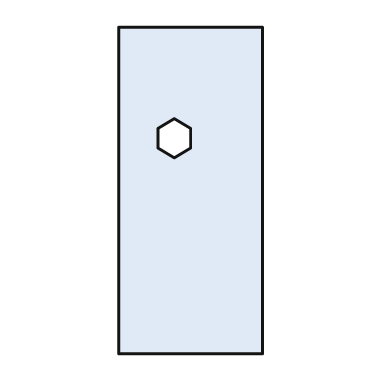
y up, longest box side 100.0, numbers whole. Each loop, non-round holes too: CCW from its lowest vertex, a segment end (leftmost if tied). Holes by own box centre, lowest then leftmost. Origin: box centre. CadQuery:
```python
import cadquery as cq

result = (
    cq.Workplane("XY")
    .moveTo(-22.0, -50.0)
    .lineTo(22.0, -50.0)
    .lineTo(22.0, 50.0)
    .lineTo(-22.0, 50.0)
    .close()
    .moveTo(-5.0, 10.0)
    .lineTo(0.0, 13.0)
    .lineTo(0.0, 19.0)
    .lineTo(-5.0, 22.0)
    .lineTo(-10.0, 19.0)
    .lineTo(-10.0, 13.0)
    .close()
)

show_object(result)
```